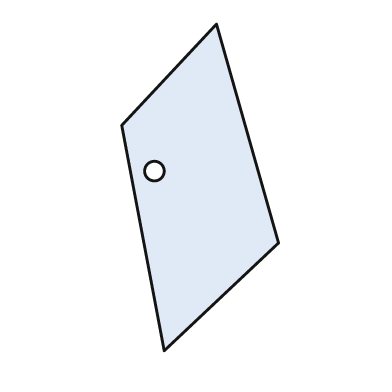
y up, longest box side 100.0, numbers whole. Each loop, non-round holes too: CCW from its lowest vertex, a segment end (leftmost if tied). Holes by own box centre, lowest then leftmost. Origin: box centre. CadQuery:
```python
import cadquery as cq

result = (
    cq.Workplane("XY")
    .moveTo(-11.0, -50.0)
    .lineTo(24.0, -17.0)
    .lineTo(5.0, 50.0)
    .lineTo(-24.0, 19.0)
    .close()
    .moveTo(-14.0, 5.0)
    .circle(3.0)
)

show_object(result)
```